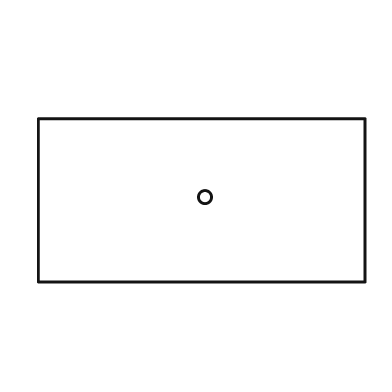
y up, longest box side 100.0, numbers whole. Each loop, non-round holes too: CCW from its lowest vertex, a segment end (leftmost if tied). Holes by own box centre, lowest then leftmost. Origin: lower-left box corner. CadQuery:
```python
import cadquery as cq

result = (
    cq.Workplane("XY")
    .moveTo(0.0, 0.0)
    .lineTo(100.0, 0.0)
    .lineTo(100.0, 50.0)
    .lineTo(0.0, 50.0)
    .close()
    .moveTo(51.0, 26.0)
    .circle(2.0)
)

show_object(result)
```